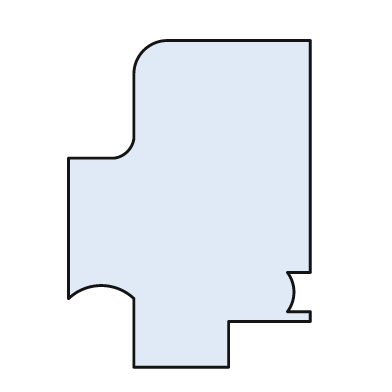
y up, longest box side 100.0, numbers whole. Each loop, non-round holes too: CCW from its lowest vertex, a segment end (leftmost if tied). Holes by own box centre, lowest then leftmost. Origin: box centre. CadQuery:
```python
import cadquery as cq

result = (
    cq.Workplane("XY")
    .moveTo(-17.0, -50.0)
    .lineTo(12.0, -50.0)
    .lineTo(12.0, -36.0)
    .lineTo(37.0, -36.0)
    .lineTo(37.0, -33.0)
    .lineTo(30.0, -33.0)
    .threePointArc((32.0, -27.0), (30.0, -21.0))
    .lineTo(37.0, -21.0)
    .lineTo(37.0, 50.0)
    .lineTo(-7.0, 50.0)
    .threePointArc((-14.0, 47.0), (-17.0, 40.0))
    .lineTo(-17.0, 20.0)
    .threePointArc((-19.0, 16.0), (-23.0, 14.0))
    .lineTo(-37.0, 14.0)
    .lineTo(-37.0, -29.0)
    .threePointArc((-27.0, -25.0), (-17.0, -29.0))
    .close()
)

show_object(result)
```